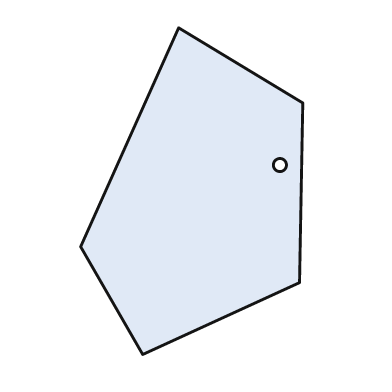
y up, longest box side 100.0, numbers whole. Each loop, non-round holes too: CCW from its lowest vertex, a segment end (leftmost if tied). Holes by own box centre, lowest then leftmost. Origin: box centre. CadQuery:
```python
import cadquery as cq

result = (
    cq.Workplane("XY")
    .moveTo(-15.0, -50.0)
    .lineTo(33.0, -28.0)
    .lineTo(34.0, 27.0)
    .lineTo(-4.0, 50.0)
    .lineTo(-34.0, -17.0)
    .close()
    .moveTo(27.0, 8.0)
    .circle(2.0)
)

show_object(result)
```